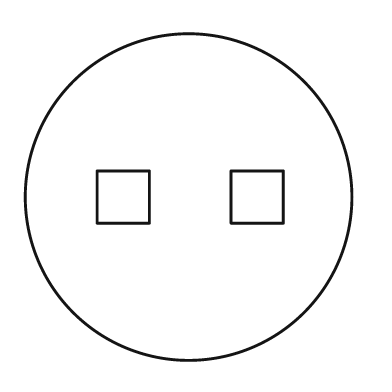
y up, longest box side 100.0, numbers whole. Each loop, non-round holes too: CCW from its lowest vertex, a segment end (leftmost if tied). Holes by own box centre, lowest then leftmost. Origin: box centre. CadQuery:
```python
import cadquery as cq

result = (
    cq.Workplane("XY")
    .moveTo(0.0, 0.0)
    .circle(50.0)
    .moveTo(-28.0, -8.0)
    .lineTo(-12.0, -8.0)
    .lineTo(-12.0, 8.0)
    .lineTo(-28.0, 8.0)
    .close()
    .moveTo(13.0, -8.0)
    .lineTo(29.0, -8.0)
    .lineTo(29.0, 8.0)
    .lineTo(13.0, 8.0)
    .close()
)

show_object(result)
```